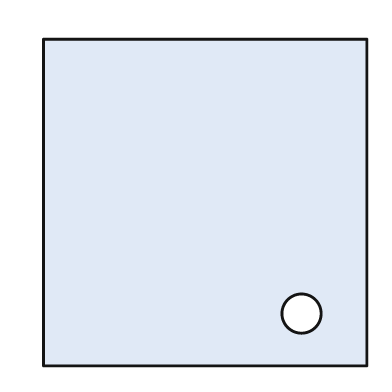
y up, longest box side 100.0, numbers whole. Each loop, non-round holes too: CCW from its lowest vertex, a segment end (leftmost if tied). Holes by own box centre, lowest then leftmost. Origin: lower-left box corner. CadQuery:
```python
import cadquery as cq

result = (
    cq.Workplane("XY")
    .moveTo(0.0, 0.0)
    .lineTo(99.0, 0.0)
    .lineTo(99.0, 100.0)
    .lineTo(0.0, 100.0)
    .close()
    .moveTo(79.0, 16.0)
    .circle(6.0)
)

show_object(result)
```